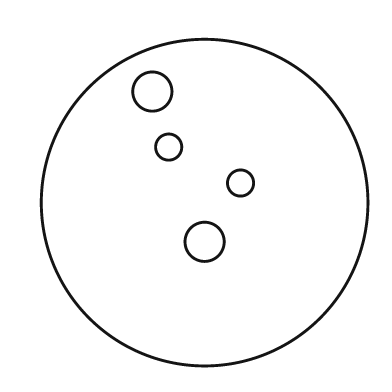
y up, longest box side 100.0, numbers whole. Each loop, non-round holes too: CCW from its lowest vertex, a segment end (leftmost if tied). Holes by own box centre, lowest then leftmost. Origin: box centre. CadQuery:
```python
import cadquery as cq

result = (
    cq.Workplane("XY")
    .moveTo(0.0, 0.0)
    .circle(50.0)
    .moveTo(0.0, -12.0)
    .circle(6.0)
    .moveTo(11.0, 6.0)
    .circle(4.0)
    .moveTo(-11.0, 17.0)
    .circle(4.0)
    .moveTo(-16.0, 34.0)
    .circle(6.0)
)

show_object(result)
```